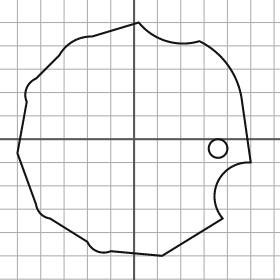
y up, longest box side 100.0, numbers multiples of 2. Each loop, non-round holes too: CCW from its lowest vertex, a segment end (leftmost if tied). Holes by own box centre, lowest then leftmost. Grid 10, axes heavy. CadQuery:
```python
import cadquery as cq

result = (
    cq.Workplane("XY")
    .moveTo(12.0, -50.0)
    .lineTo(38.0, -34.0)
    .threePointArc((36.0, -18.0), (50.0, -10.0))
    .lineTo(46.0, 18.0)
    .threePointArc((40.0, 32.0), (28.0, 42.0))
    .threePointArc((14.0, 42.0), (2.0, 50.0))
    .lineTo(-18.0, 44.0)
    .threePointArc((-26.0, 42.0), (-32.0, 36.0))
    .lineTo(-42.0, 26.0)
    .threePointArc((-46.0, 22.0), (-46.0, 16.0))
    .lineTo(-50.0, -6.0)
    .lineTo(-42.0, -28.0)
    .threePointArc((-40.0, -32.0), (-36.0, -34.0))
    .lineTo(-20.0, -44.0)
    .threePointArc((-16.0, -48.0), (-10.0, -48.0))
    .close()
    .moveTo(36.0, -4.0)
    .circle(4.0)
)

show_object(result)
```